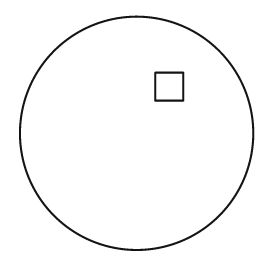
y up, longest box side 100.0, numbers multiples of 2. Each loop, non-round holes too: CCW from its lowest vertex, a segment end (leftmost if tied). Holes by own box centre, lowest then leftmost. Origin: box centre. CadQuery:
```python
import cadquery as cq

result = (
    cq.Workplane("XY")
    .moveTo(0.0, 0.0)
    .circle(50.0)
    .moveTo(8.0, 14.0)
    .lineTo(20.0, 14.0)
    .lineTo(20.0, 26.0)
    .lineTo(8.0, 26.0)
    .close()
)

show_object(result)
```